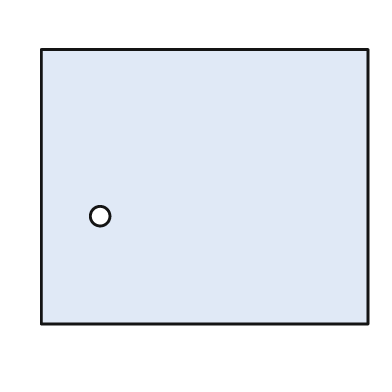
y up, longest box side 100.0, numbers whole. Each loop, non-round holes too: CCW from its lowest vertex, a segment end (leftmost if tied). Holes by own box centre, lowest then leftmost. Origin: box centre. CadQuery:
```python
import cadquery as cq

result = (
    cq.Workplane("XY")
    .moveTo(-50.0, -42.0)
    .lineTo(50.0, -42.0)
    .lineTo(50.0, 42.0)
    .lineTo(-50.0, 42.0)
    .close()
    .moveTo(-32.0, -9.0)
    .circle(3.0)
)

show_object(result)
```